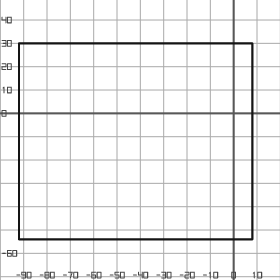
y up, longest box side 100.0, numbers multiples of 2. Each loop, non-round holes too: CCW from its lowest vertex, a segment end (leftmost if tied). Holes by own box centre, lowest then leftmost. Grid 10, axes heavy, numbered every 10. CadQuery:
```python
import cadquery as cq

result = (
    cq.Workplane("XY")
    .moveTo(-92.0, -54.0)
    .lineTo(8.0, -54.0)
    .lineTo(8.0, 30.0)
    .lineTo(-92.0, 30.0)
    .close()
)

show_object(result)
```